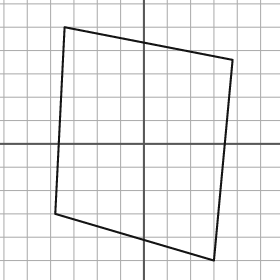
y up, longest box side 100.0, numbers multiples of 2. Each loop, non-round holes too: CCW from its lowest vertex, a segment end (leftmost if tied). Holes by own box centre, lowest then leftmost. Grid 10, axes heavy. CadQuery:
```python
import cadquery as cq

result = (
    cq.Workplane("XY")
    .moveTo(30.0, -50.0)
    .lineTo(38.0, 36.0)
    .lineTo(-34.0, 50.0)
    .lineTo(-38.0, -30.0)
    .close()
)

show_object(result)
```